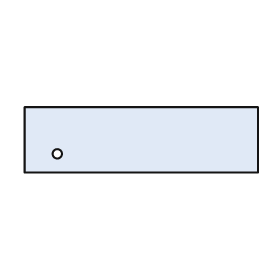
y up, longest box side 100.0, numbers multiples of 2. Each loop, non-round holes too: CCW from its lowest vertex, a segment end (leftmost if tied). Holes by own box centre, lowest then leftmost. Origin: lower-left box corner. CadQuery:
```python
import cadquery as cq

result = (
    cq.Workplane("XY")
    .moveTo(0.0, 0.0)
    .lineTo(100.0, 0.0)
    .lineTo(100.0, 28.0)
    .lineTo(0.0, 28.0)
    .close()
    .moveTo(14.0, 8.0)
    .circle(2.0)
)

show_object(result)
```